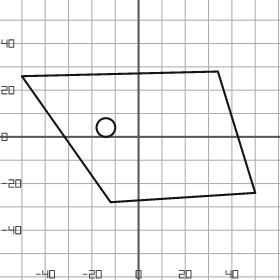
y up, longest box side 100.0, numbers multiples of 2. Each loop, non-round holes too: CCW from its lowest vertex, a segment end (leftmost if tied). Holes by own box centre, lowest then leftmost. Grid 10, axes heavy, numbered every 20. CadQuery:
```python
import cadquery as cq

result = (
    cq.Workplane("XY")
    .moveTo(-12.0, -28.0)
    .lineTo(50.0, -24.0)
    .lineTo(34.0, 28.0)
    .lineTo(-50.0, 26.0)
    .close()
    .moveTo(-14.0, 4.0)
    .circle(4.0)
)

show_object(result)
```